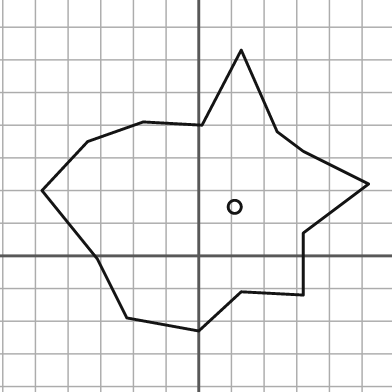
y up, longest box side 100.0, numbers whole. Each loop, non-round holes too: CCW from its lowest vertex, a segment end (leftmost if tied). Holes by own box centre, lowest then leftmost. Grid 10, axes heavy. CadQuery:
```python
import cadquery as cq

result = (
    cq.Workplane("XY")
    .moveTo(0.0, -23.0)
    .lineTo(13.0, -11.0)
    .lineTo(32.0, -12.0)
    .lineTo(32.0, 7.0)
    .lineTo(52.0, 22.0)
    .lineTo(32.0, 32.0)
    .lineTo(24.0, 38.0)
    .lineTo(13.0, 63.0)
    .lineTo(1.0, 40.0)
    .lineTo(-17.0, 41.0)
    .lineTo(-34.0, 35.0)
    .lineTo(-48.0, 20.0)
    .lineTo(-31.0, -1.0)
    .lineTo(-22.0, -19.0)
    .close()
    .moveTo(11.0, 15.0)
    .circle(2.0)
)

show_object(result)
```